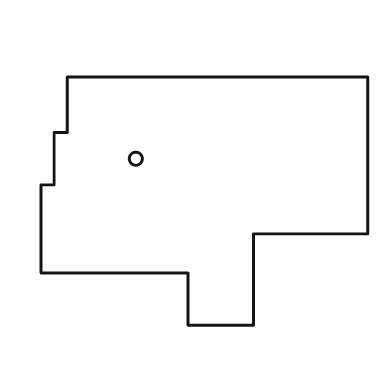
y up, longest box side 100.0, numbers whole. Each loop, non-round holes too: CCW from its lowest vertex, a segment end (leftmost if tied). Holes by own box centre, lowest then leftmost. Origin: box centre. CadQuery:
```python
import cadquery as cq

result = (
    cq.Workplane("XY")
    .moveTo(-5.0, -38.0)
    .lineTo(15.0, -38.0)
    .lineTo(15.0, -10.0)
    .lineTo(50.0, -10.0)
    .lineTo(50.0, 38.0)
    .lineTo(-42.0, 38.0)
    .lineTo(-42.0, 21.0)
    .lineTo(-46.0, 21.0)
    .lineTo(-46.0, 5.0)
    .lineTo(-50.0, 5.0)
    .lineTo(-50.0, -22.0)
    .lineTo(-5.0, -22.0)
    .close()
    .moveTo(-21.0, 13.0)
    .circle(2.0)
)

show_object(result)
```